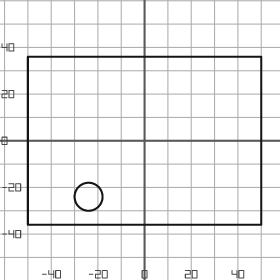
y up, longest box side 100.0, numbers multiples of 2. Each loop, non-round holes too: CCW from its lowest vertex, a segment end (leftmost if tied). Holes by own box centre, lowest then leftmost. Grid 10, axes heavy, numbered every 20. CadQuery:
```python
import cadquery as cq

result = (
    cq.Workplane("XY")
    .moveTo(-50.0, -36.0)
    .lineTo(50.0, -36.0)
    .lineTo(50.0, 36.0)
    .lineTo(-50.0, 36.0)
    .close()
    .moveTo(-24.0, -24.0)
    .circle(6.0)
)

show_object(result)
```